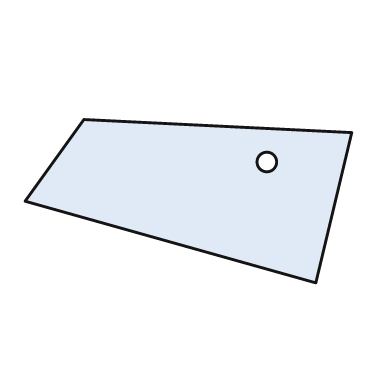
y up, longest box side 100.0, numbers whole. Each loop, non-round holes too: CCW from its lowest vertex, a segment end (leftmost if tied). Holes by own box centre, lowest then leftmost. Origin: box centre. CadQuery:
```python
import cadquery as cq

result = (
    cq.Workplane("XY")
    .moveTo(39.0, -25.0)
    .lineTo(50.0, 21.0)
    .lineTo(-32.0, 25.0)
    .lineTo(-50.0, 0.0)
    .close()
    .moveTo(24.0, 12.0)
    .circle(3.0)
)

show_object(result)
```